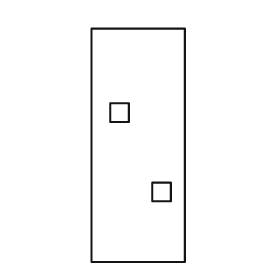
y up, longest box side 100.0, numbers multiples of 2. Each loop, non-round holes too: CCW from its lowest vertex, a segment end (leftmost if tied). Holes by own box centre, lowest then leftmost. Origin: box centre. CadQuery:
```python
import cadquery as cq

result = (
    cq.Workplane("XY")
    .moveTo(-20.0, -50.0)
    .lineTo(20.0, -50.0)
    .lineTo(20.0, 50.0)
    .lineTo(-20.0, 50.0)
    .close()
    .moveTo(6.0, -24.0)
    .lineTo(14.0, -24.0)
    .lineTo(14.0, -16.0)
    .lineTo(6.0, -16.0)
    .close()
    .moveTo(-12.0, 10.0)
    .lineTo(-4.0, 10.0)
    .lineTo(-4.0, 18.0)
    .lineTo(-12.0, 18.0)
    .close()
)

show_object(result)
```